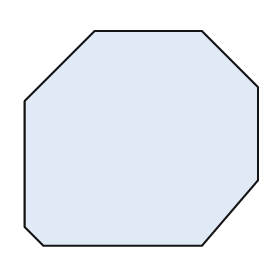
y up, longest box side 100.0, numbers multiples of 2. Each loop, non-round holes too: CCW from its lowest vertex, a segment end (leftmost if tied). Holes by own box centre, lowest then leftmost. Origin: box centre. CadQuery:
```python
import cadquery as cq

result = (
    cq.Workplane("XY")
    .moveTo(-42.0, -46.0)
    .lineTo(26.0, -46.0)
    .lineTo(50.0, -18.0)
    .lineTo(50.0, 22.0)
    .lineTo(26.0, 46.0)
    .lineTo(-20.0, 46.0)
    .lineTo(-50.0, 16.0)
    .lineTo(-50.0, -38.0)
    .close()
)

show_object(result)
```